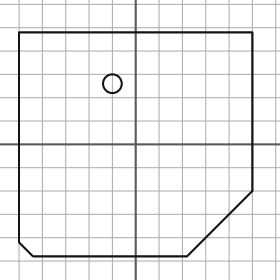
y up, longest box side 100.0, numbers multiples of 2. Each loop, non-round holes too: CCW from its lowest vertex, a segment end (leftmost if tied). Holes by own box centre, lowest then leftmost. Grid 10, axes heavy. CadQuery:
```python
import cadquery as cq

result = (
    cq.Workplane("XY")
    .moveTo(-44.0, -48.0)
    .lineTo(22.0, -48.0)
    .lineTo(50.0, -20.0)
    .lineTo(50.0, 48.0)
    .lineTo(-50.0, 48.0)
    .lineTo(-50.0, -42.0)
    .close()
    .moveTo(-10.0, 26.0)
    .circle(4.0)
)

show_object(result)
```